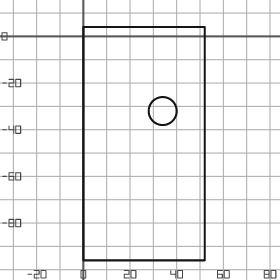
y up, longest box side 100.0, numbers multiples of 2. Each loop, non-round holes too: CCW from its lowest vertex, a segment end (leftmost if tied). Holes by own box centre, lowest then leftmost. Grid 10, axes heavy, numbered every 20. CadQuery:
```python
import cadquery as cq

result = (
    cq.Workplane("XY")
    .moveTo(0.0, -96.0)
    .lineTo(52.0, -96.0)
    .lineTo(52.0, 4.0)
    .lineTo(0.0, 4.0)
    .close()
    .moveTo(34.0, -32.0)
    .circle(6.0)
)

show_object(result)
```